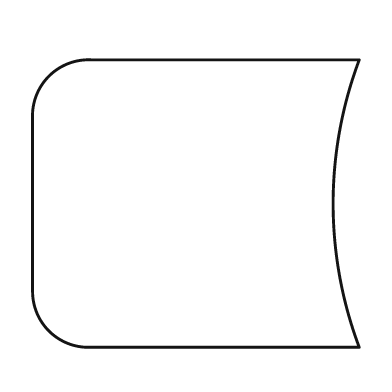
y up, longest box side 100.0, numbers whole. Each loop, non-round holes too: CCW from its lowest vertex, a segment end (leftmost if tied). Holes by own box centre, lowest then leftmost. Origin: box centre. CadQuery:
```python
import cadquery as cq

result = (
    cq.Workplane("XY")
    .moveTo(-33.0, -44.0)
    .lineTo(50.0, -44.0)
    .threePointArc((42.0, 0.0), (50.0, 44.0))
    .lineTo(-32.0, 44.0)
    .threePointArc((-45.0, 39.0), (-50.0, 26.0))
    .lineTo(-50.0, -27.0)
    .threePointArc((-45.0, -39.0), (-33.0, -44.0))
    .close()
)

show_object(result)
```